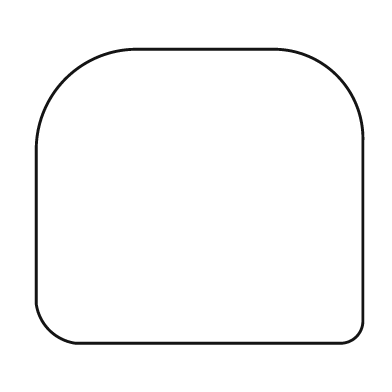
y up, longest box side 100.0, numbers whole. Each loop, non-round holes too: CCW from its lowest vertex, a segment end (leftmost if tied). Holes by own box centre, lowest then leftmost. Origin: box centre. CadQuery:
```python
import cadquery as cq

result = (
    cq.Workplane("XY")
    .moveTo(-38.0, -45.0)
    .lineTo(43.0, -45.0)
    .threePointArc((48.0, -43.0), (50.0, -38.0))
    .lineTo(50.0, 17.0)
    .threePointArc((42.0, 37.0), (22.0, 45.0))
    .lineTo(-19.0, 45.0)
    .threePointArc((-41.0, 36.0), (-50.0, 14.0))
    .lineTo(-50.0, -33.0)
    .threePointArc((-46.0, -41.0), (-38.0, -45.0))
    .close()
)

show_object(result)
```